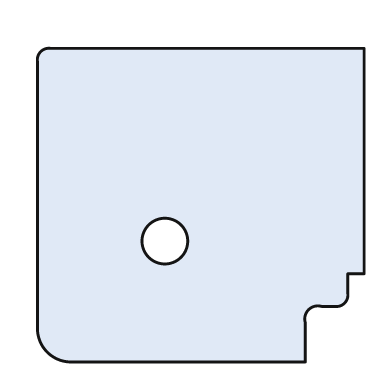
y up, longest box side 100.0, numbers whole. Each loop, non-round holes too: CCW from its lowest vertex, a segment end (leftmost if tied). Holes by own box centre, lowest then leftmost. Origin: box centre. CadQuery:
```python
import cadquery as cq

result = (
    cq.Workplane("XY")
    .moveTo(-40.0, -48.0)
    .lineTo(32.0, -48.0)
    .lineTo(32.0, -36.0)
    .threePointArc((33.0, -32.0), (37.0, -31.0))
    .lineTo(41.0, -31.0)
    .threePointArc((44.0, -30.0), (45.0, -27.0))
    .lineTo(45.0, -21.0)
    .lineTo(50.0, -21.0)
    .lineTo(50.0, 48.0)
    .lineTo(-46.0, 48.0)
    .threePointArc((-49.0, 47.0), (-50.0, 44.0))
    .lineTo(-50.0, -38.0)
    .threePointArc((-47.0, -45.0), (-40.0, -48.0))
    .close()
    .moveTo(-11.0, -11.0)
    .circle(7.0)
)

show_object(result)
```